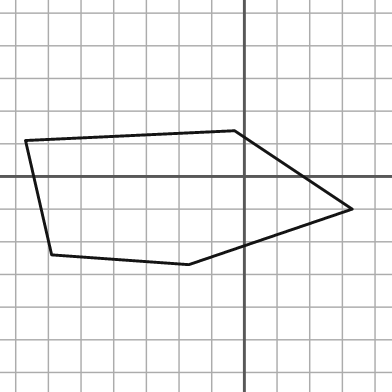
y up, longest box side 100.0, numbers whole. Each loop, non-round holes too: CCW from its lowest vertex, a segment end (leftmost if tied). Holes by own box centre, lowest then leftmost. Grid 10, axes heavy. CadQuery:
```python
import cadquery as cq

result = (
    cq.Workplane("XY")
    .moveTo(-17.0, -27.0)
    .lineTo(33.0, -10.0)
    .lineTo(-3.0, 14.0)
    .lineTo(-67.0, 11.0)
    .lineTo(-59.0, -24.0)
    .close()
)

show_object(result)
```